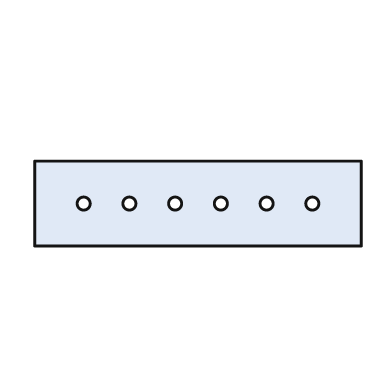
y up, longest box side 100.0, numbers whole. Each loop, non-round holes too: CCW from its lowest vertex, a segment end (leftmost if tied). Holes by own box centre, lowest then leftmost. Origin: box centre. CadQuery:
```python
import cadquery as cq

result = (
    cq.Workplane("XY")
    .moveTo(-50.0, -13.0)
    .lineTo(50.0, -13.0)
    .lineTo(50.0, 13.0)
    .lineTo(-50.0, 13.0)
    .close()
    .moveTo(-35.0, 0.0)
    .circle(2.0)
    .moveTo(-21.0, 0.0)
    .circle(2.0)
    .moveTo(-7.0, 0.0)
    .circle(2.0)
    .moveTo(7.0, 0.0)
    .circle(2.0)
    .moveTo(21.0, 0.0)
    .circle(2.0)
    .moveTo(35.0, 0.0)
    .circle(2.0)
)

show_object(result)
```